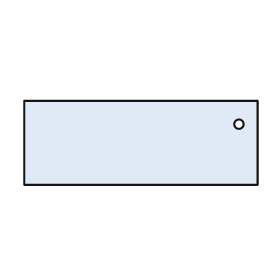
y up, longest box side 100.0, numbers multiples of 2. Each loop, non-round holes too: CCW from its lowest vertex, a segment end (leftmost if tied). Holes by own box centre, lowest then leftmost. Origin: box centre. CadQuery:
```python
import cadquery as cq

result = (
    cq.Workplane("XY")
    .moveTo(-50.0, -18.0)
    .lineTo(50.0, -18.0)
    .lineTo(50.0, 18.0)
    .lineTo(-50.0, 18.0)
    .close()
    .moveTo(42.0, 8.0)
    .circle(2.0)
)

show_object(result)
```